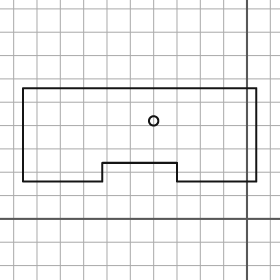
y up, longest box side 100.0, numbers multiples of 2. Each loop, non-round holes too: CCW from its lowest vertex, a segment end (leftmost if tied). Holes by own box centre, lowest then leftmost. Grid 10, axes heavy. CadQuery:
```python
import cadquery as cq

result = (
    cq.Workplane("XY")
    .moveTo(-96.0, 16.0)
    .lineTo(-62.0, 16.0)
    .lineTo(-62.0, 24.0)
    .lineTo(-30.0, 24.0)
    .lineTo(-30.0, 16.0)
    .lineTo(4.0, 16.0)
    .lineTo(4.0, 56.0)
    .lineTo(-96.0, 56.0)
    .close()
    .moveTo(-40.0, 42.0)
    .circle(2.0)
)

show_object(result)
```